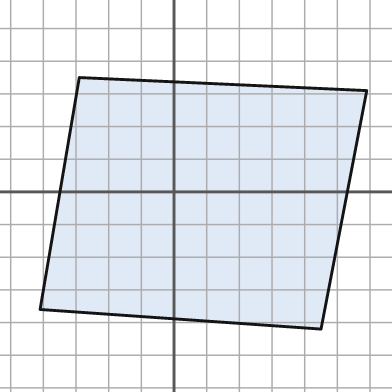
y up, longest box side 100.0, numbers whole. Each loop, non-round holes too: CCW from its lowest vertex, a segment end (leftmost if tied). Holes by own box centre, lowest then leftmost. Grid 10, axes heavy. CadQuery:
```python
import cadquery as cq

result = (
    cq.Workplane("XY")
    .moveTo(45.0, -42.0)
    .lineTo(59.0, 31.0)
    .lineTo(-29.0, 35.0)
    .lineTo(-41.0, -36.0)
    .close()
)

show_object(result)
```